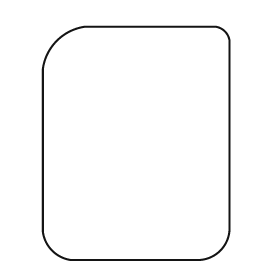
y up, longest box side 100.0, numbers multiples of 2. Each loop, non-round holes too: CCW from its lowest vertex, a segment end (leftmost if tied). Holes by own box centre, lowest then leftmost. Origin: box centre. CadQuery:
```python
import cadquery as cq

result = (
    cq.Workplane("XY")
    .moveTo(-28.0, -50.0)
    .lineTo(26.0, -50.0)
    .threePointArc((36.0, -46.0), (40.0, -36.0))
    .lineTo(40.0, 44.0)
    .threePointArc((38.0, 48.0), (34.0, 50.0))
    .lineTo(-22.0, 50.0)
    .threePointArc((-34.0, 44.0), (-40.0, 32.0))
    .lineTo(-40.0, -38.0)
    .threePointArc((-36.0, -46.0), (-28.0, -50.0))
    .close()
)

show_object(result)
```